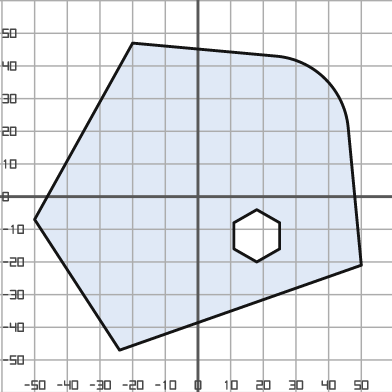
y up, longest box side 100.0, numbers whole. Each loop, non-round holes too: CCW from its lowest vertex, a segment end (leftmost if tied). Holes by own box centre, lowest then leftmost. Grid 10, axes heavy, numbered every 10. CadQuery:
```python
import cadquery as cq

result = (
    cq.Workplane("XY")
    .moveTo(-24.0, -47.0)
    .lineTo(50.0, -21.0)
    .lineTo(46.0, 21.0)
    .threePointArc((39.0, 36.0), (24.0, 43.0))
    .lineTo(-20.0, 47.0)
    .lineTo(-50.0, -7.0)
    .close()
    .moveTo(18.0, -20.0)
    .lineTo(25.0, -16.0)
    .lineTo(25.0, -8.0)
    .lineTo(18.0, -4.0)
    .lineTo(11.0, -8.0)
    .lineTo(11.0, -16.0)
    .close()
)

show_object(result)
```